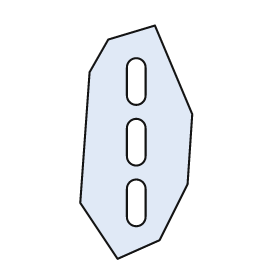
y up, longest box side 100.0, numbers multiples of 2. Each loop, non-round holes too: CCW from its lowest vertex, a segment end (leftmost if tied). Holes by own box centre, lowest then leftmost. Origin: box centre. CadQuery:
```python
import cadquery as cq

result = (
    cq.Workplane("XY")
    .moveTo(-8.0, -50.0)
    .lineTo(10.0, -42.0)
    .lineTo(22.0, -18.0)
    .lineTo(24.0, 12.0)
    .lineTo(8.0, 50.0)
    .lineTo(-12.0, 44.0)
    .lineTo(-20.0, 30.0)
    .lineTo(-24.0, -26.0)
    .close()
    .moveTo(-4.0, -32.0)
    .threePointArc((0.0, -36.0), (4.0, -32.0))
    .lineTo(4.0, -20.0)
    .threePointArc((0.0, -16.0), (-4.0, -20.0))
    .close()
    .moveTo(-4.0, -6.0)
    .threePointArc((0.0, -10.0), (4.0, -6.0))
    .lineTo(4.0, 6.0)
    .threePointArc((0.0, 10.0), (-4.0, 6.0))
    .close()
    .moveTo(-4.0, 20.0)
    .threePointArc((0.0, 16.0), (4.0, 20.0))
    .lineTo(4.0, 32.0)
    .threePointArc((0.0, 36.0), (-4.0, 32.0))
    .close()
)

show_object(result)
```